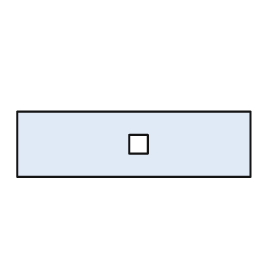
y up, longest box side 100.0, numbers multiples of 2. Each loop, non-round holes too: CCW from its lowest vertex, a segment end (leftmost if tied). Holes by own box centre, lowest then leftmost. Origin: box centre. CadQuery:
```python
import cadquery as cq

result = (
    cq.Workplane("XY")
    .moveTo(-50.0, -14.0)
    .lineTo(50.0, -14.0)
    .lineTo(50.0, 14.0)
    .lineTo(-50.0, 14.0)
    .close()
    .moveTo(-2.0, -4.0)
    .lineTo(6.0, -4.0)
    .lineTo(6.0, 4.0)
    .lineTo(-2.0, 4.0)
    .close()
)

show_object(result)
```